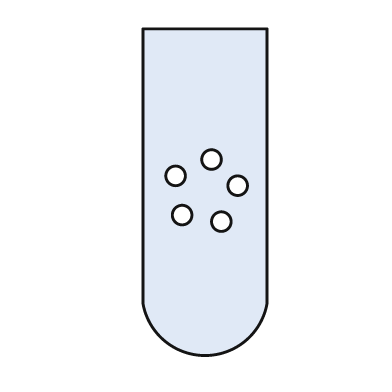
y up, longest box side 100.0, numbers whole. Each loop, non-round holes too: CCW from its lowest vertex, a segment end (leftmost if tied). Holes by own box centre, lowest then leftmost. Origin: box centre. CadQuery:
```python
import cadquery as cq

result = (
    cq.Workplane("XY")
    .moveTo(-19.0, -34.0)
    .threePointArc((0.0, -50.0), (19.0, -34.0))
    .lineTo(19.0, 50.0)
    .lineTo(-19.0, 50.0)
    .close()
    .moveTo(5.0, -9.0)
    .circle(3.0)
    .moveTo(-7.0, -7.0)
    .circle(3.0)
    .moveTo(10.0, 2.0)
    .circle(3.0)
    .moveTo(-9.0, 5.0)
    .circle(3.0)
    .moveTo(2.0, 10.0)
    .circle(3.0)
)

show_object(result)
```